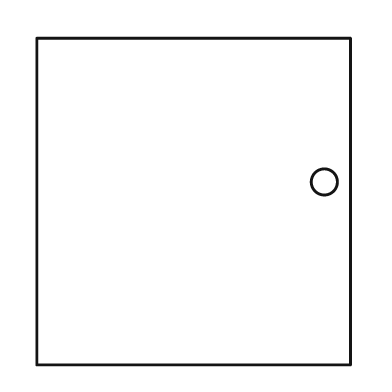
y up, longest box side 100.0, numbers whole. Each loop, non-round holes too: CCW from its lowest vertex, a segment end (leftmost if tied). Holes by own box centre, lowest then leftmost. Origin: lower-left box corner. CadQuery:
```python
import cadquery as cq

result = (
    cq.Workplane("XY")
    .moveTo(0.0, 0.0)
    .lineTo(96.0, 0.0)
    .lineTo(96.0, 100.0)
    .lineTo(0.0, 100.0)
    .close()
    .moveTo(88.0, 56.0)
    .circle(4.0)
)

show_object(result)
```